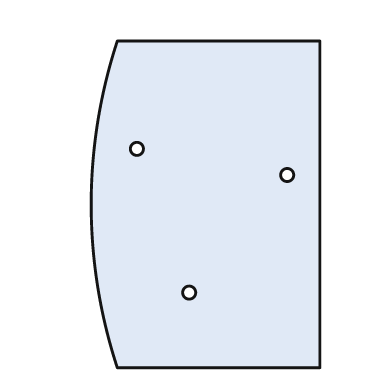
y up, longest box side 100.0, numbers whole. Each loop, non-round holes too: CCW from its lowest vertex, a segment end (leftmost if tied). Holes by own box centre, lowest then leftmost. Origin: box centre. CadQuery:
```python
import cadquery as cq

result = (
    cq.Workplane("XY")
    .moveTo(-27.0, -50.0)
    .lineTo(35.0, -50.0)
    .lineTo(35.0, 50.0)
    .lineTo(-27.0, 50.0)
    .threePointArc((-35.0, 0.0), (-27.0, -50.0))
    .close()
    .moveTo(-5.0, -27.0)
    .circle(2.0)
    .moveTo(25.0, 9.0)
    .circle(2.0)
    .moveTo(-21.0, 17.0)
    .circle(2.0)
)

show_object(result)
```